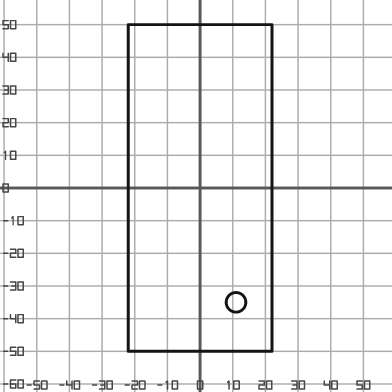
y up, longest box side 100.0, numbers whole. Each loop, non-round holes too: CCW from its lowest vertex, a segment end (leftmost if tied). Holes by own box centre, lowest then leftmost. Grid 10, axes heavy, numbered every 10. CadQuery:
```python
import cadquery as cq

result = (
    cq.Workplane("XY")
    .moveTo(-22.0, -50.0)
    .lineTo(22.0, -50.0)
    .lineTo(22.0, 50.0)
    .lineTo(-22.0, 50.0)
    .close()
    .moveTo(11.0, -35.0)
    .circle(3.0)
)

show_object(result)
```